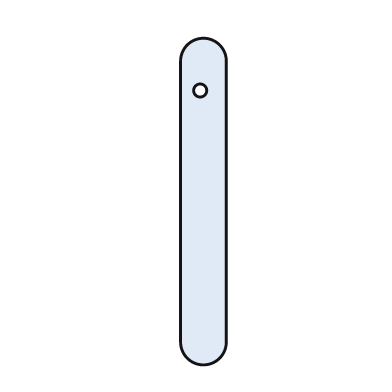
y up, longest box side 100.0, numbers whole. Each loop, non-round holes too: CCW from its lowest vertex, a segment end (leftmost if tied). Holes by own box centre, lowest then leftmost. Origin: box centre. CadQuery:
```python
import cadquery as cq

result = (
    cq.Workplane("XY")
    .moveTo(-7.0, -43.0)
    .threePointArc((0.0, -50.0), (7.0, -43.0))
    .lineTo(7.0, 43.0)
    .threePointArc((0.0, 50.0), (-7.0, 43.0))
    .close()
    .moveTo(-1.0, 34.0)
    .circle(2.0)
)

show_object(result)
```